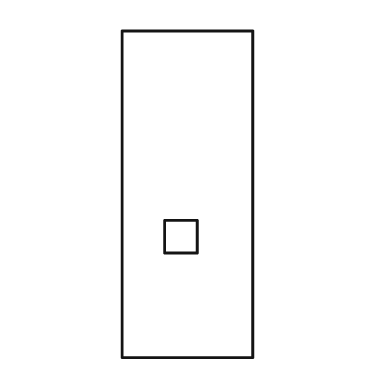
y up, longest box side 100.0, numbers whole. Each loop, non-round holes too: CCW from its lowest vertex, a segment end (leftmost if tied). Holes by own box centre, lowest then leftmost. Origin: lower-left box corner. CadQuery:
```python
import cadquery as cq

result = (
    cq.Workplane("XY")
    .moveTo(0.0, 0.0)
    .lineTo(40.0, 0.0)
    .lineTo(40.0, 100.0)
    .lineTo(0.0, 100.0)
    .close()
    .moveTo(13.0, 32.0)
    .lineTo(23.0, 32.0)
    .lineTo(23.0, 42.0)
    .lineTo(13.0, 42.0)
    .close()
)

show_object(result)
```